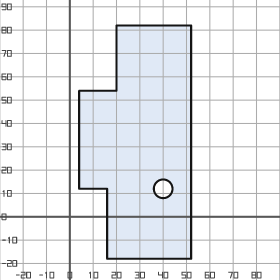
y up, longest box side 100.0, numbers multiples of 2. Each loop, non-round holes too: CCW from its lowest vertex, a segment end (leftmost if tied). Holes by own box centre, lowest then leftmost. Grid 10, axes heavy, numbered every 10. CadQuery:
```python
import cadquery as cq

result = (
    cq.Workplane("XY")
    .moveTo(16.0, -18.0)
    .lineTo(52.0, -18.0)
    .lineTo(52.0, 82.0)
    .lineTo(20.0, 82.0)
    .lineTo(20.0, 54.0)
    .lineTo(4.0, 54.0)
    .lineTo(4.0, 12.0)
    .lineTo(16.0, 12.0)
    .close()
    .moveTo(40.0, 12.0)
    .circle(4.0)
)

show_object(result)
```